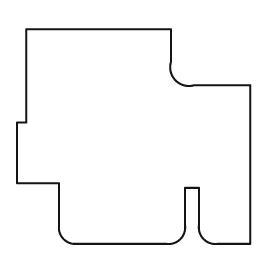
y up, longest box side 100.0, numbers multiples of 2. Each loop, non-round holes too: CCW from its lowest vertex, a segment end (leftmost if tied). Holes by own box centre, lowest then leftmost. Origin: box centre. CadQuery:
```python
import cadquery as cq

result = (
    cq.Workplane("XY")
    .moveTo(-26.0, -46.0)
    .lineTo(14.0, -46.0)
    .threePointArc((20.0, -44.0), (22.0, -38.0))
    .lineTo(22.0, -22.0)
    .lineTo(28.0, -22.0)
    .lineTo(28.0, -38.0)
    .threePointArc((30.0, -44.0), (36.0, -46.0))
    .lineTo(50.0, -46.0)
    .lineTo(50.0, 22.0)
    .lineTo(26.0, 22.0)
    .threePointArc((18.0, 24.0), (16.0, 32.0))
    .lineTo(16.0, 46.0)
    .lineTo(-46.0, 46.0)
    .lineTo(-46.0, 6.0)
    .lineTo(-50.0, 6.0)
    .lineTo(-50.0, -20.0)
    .lineTo(-32.0, -20.0)
    .lineTo(-32.0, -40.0)
    .threePointArc((-30.0, -44.0), (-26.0, -46.0))
    .close()
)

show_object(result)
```